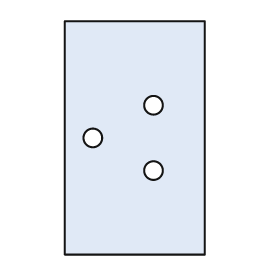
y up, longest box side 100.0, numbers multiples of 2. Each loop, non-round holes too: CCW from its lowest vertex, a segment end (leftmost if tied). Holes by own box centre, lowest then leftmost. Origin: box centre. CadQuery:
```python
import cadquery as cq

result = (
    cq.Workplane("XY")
    .moveTo(-30.0, -50.0)
    .lineTo(30.0, -50.0)
    .lineTo(30.0, 50.0)
    .lineTo(-30.0, 50.0)
    .close()
    .moveTo(8.0, -14.0)
    .circle(4.0)
    .moveTo(-18.0, 0.0)
    .circle(4.0)
    .moveTo(8.0, 14.0)
    .circle(4.0)
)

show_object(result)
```